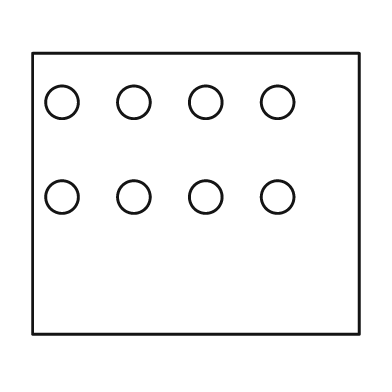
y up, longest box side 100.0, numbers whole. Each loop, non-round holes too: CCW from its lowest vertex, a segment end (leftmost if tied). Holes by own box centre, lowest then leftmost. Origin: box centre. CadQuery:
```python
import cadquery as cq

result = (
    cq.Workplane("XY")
    .moveTo(-50.0, -43.0)
    .lineTo(50.0, -43.0)
    .lineTo(50.0, 43.0)
    .lineTo(-50.0, 43.0)
    .close()
    .moveTo(-41.0, -1.0)
    .circle(5.0)
    .moveTo(-19.0, -1.0)
    .circle(5.0)
    .moveTo(3.0, -1.0)
    .circle(5.0)
    .moveTo(25.0, -1.0)
    .circle(5.0)
    .moveTo(-41.0, 28.0)
    .circle(5.0)
    .moveTo(-19.0, 28.0)
    .circle(5.0)
    .moveTo(3.0, 28.0)
    .circle(5.0)
    .moveTo(25.0, 28.0)
    .circle(5.0)
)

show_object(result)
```